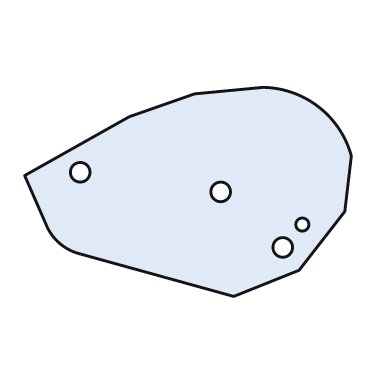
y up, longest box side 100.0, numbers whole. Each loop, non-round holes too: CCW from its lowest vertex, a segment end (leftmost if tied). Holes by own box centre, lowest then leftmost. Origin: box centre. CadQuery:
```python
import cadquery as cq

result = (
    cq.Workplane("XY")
    .moveTo(14.0, -32.0)
    .lineTo(34.0, -24.0)
    .lineTo(48.0, -6.0)
    .lineTo(50.0, 11.0)
    .threePointArc((40.0, 26.0), (23.0, 32.0))
    .lineTo(2.0, 30.0)
    .lineTo(-18.0, 23.0)
    .lineTo(-50.0, 5.0)
    .lineTo(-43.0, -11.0)
    .threePointArc((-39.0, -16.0), (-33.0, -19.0))
    .close()
    .moveTo(29.0, -17.0)
    .circle(3.0)
    .moveTo(35.0, -10.0)
    .circle(2.0)
    .moveTo(10.0, 0.0)
    .circle(3.0)
    .moveTo(-33.0, 6.0)
    .circle(3.0)
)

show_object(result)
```